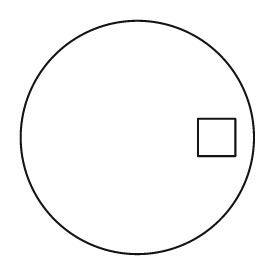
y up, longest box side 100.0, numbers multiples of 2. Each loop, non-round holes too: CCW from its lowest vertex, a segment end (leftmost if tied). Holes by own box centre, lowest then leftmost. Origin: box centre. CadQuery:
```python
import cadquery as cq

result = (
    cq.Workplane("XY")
    .moveTo(0.0, 0.0)
    .circle(50.0)
    .moveTo(26.0, -8.0)
    .lineTo(42.0, -8.0)
    .lineTo(42.0, 8.0)
    .lineTo(26.0, 8.0)
    .close()
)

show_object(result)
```